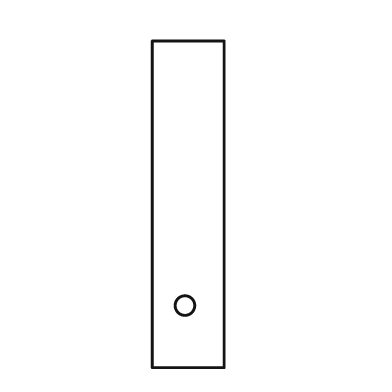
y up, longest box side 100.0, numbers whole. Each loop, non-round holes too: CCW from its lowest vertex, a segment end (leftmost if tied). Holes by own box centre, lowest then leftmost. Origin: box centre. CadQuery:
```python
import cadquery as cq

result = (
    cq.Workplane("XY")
    .moveTo(-11.0, -50.0)
    .lineTo(11.0, -50.0)
    .lineTo(11.0, 50.0)
    .lineTo(-11.0, 50.0)
    .close()
    .moveTo(-1.0, -31.0)
    .circle(3.0)
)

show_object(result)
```